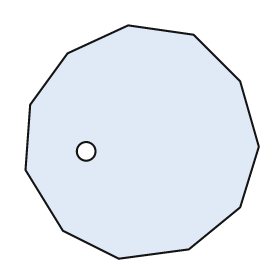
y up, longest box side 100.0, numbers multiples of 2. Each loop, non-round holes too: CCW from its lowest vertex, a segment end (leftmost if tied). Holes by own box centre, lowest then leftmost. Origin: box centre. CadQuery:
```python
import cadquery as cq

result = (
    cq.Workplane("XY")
    .moveTo(-10.0, -50.0)
    .lineTo(20.0, -46.0)
    .lineTo(42.0, -28.0)
    .lineTo(50.0, -2.0)
    .lineTo(42.0, 26.0)
    .lineTo(22.0, 46.0)
    .lineTo(-6.0, 50.0)
    .lineTo(-32.0, 38.0)
    .lineTo(-48.0, 16.0)
    .lineTo(-50.0, -12.0)
    .lineTo(-34.0, -38.0)
    .close()
    .moveTo(-24.0, -4.0)
    .circle(4.0)
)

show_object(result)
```